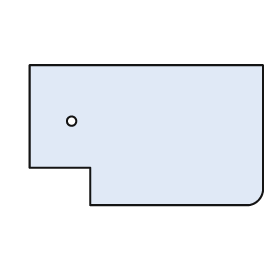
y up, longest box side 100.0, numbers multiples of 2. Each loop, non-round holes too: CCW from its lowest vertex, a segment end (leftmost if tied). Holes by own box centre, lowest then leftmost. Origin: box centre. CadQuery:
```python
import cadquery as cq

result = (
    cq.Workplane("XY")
    .moveTo(-24.0, -30.0)
    .lineTo(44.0, -30.0)
    .threePointArc((48.0, -28.0), (50.0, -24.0))
    .lineTo(50.0, 30.0)
    .lineTo(-50.0, 30.0)
    .lineTo(-50.0, -14.0)
    .lineTo(-24.0, -14.0)
    .close()
    .moveTo(-32.0, 6.0)
    .circle(2.0)
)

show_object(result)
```